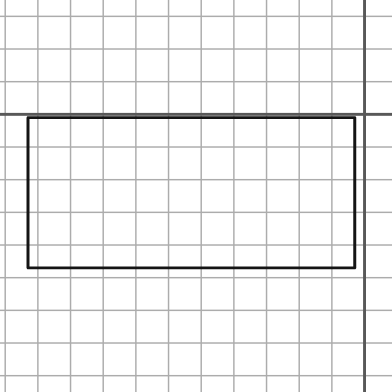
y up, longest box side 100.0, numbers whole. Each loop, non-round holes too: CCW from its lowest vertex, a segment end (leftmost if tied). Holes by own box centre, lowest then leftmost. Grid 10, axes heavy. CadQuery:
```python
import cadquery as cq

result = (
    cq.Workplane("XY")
    .moveTo(-103.0, -47.0)
    .lineTo(-3.0, -47.0)
    .lineTo(-3.0, -1.0)
    .lineTo(-103.0, -1.0)
    .close()
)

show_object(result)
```